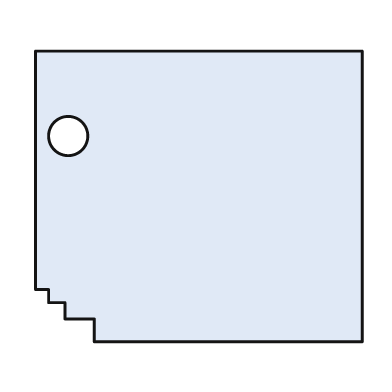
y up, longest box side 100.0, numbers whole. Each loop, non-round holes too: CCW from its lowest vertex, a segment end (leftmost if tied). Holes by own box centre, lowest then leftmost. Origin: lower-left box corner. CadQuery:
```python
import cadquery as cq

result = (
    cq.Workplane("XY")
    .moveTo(18.0, 0.0)
    .lineTo(100.0, 0.0)
    .lineTo(100.0, 89.0)
    .lineTo(0.0, 89.0)
    .lineTo(0.0, 16.0)
    .lineTo(4.0, 16.0)
    .lineTo(4.0, 12.0)
    .lineTo(9.0, 12.0)
    .lineTo(9.0, 7.0)
    .lineTo(18.0, 7.0)
    .close()
    .moveTo(10.0, 63.0)
    .circle(6.0)
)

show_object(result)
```